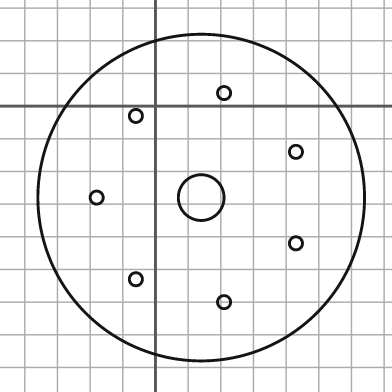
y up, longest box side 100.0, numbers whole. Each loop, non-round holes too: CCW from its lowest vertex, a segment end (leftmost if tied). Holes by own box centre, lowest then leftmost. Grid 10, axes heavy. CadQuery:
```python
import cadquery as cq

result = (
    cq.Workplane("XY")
    .moveTo(14.0, -28.0)
    .circle(50.0)
    .moveTo(21.0, -60.0)
    .circle(2.0)
    .moveTo(-6.0, -53.0)
    .circle(2.0)
    .moveTo(43.0, -42.0)
    .circle(2.0)
    .moveTo(-18.0, -28.0)
    .circle(2.0)
    .moveTo(14.0, -28.0)
    .circle(7.0)
    .moveTo(43.0, -14.0)
    .circle(2.0)
    .moveTo(-6.0, -3.0)
    .circle(2.0)
    .moveTo(21.0, 4.0)
    .circle(2.0)
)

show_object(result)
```